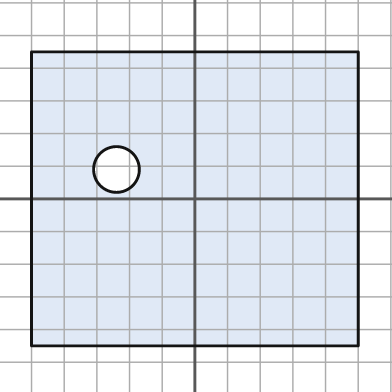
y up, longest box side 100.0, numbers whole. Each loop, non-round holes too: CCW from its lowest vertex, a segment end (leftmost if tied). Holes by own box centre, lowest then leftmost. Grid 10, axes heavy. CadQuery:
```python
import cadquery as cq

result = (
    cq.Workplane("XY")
    .moveTo(-50.0, -45.0)
    .lineTo(50.0, -45.0)
    .lineTo(50.0, 45.0)
    .lineTo(-50.0, 45.0)
    .close()
    .moveTo(-24.0, 9.0)
    .circle(7.0)
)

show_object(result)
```